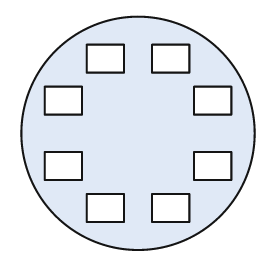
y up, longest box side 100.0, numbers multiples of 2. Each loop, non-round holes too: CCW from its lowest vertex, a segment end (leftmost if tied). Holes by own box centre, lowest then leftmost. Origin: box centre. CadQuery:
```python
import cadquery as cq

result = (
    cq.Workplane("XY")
    .moveTo(0.0, 0.0)
    .circle(50.0)
    .moveTo(-22.0, -38.0)
    .lineTo(-6.0, -38.0)
    .lineTo(-6.0, -26.0)
    .lineTo(-22.0, -26.0)
    .close()
    .moveTo(6.0, -38.0)
    .lineTo(22.0, -38.0)
    .lineTo(22.0, -26.0)
    .lineTo(6.0, -26.0)
    .close()
    .moveTo(-40.0, -20.0)
    .lineTo(-24.0, -20.0)
    .lineTo(-24.0, -8.0)
    .lineTo(-40.0, -8.0)
    .close()
    .moveTo(24.0, -20.0)
    .lineTo(40.0, -20.0)
    .lineTo(40.0, -8.0)
    .lineTo(24.0, -8.0)
    .close()
    .moveTo(-40.0, 8.0)
    .lineTo(-24.0, 8.0)
    .lineTo(-24.0, 20.0)
    .lineTo(-40.0, 20.0)
    .close()
    .moveTo(24.0, 8.0)
    .lineTo(40.0, 8.0)
    .lineTo(40.0, 20.0)
    .lineTo(24.0, 20.0)
    .close()
    .moveTo(-22.0, 26.0)
    .lineTo(-6.0, 26.0)
    .lineTo(-6.0, 38.0)
    .lineTo(-22.0, 38.0)
    .close()
    .moveTo(6.0, 26.0)
    .lineTo(22.0, 26.0)
    .lineTo(22.0, 38.0)
    .lineTo(6.0, 38.0)
    .close()
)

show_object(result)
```